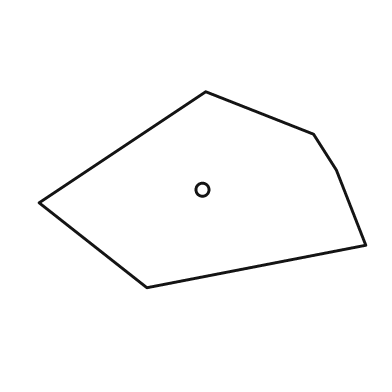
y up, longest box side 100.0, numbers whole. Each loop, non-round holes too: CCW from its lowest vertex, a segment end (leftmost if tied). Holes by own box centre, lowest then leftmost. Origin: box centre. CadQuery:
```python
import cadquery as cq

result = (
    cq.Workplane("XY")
    .moveTo(-17.0, -30.0)
    .lineTo(50.0, -17.0)
    .lineTo(41.0, 6.0)
    .lineTo(34.0, 17.0)
    .lineTo(1.0, 30.0)
    .lineTo(-50.0, -4.0)
    .close()
    .moveTo(0.0, 0.0)
    .circle(2.0)
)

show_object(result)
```